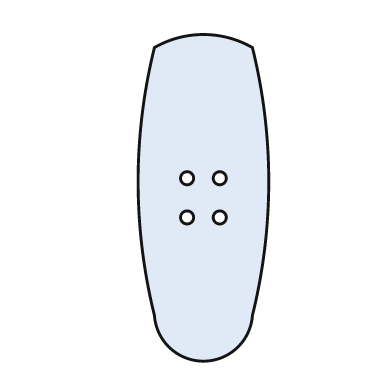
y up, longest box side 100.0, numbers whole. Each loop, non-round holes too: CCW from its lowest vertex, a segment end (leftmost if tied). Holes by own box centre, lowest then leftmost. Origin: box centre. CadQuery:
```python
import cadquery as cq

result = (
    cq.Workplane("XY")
    .moveTo(-15.0, -36.0)
    .threePointArc((0.0, -50.0), (15.0, -36.0))
    .threePointArc((20.0, 5.0), (15.0, 46.0))
    .threePointArc((0.0, 50.0), (-15.0, 46.0))
    .threePointArc((-20.0, 5.0), (-15.0, -36.0))
    .close()
    .moveTo(-5.0, -6.0)
    .circle(2.0)
    .moveTo(5.0, -6.0)
    .circle(2.0)
    .moveTo(-5.0, 6.0)
    .circle(2.0)
    .moveTo(5.0, 6.0)
    .circle(2.0)
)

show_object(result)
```